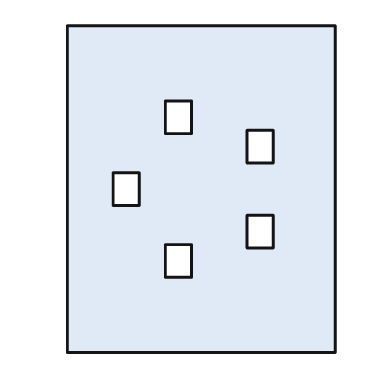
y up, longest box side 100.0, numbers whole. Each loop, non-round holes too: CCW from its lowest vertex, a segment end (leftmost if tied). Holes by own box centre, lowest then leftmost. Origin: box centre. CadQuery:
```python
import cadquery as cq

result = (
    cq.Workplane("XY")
    .moveTo(-41.0, -50.0)
    .lineTo(41.0, -50.0)
    .lineTo(41.0, 50.0)
    .lineTo(-41.0, 50.0)
    .close()
    .moveTo(-11.0, -27.0)
    .lineTo(-3.0, -27.0)
    .lineTo(-3.0, -17.0)
    .lineTo(-11.0, -17.0)
    .close()
    .moveTo(14.0, -18.0)
    .lineTo(22.0, -18.0)
    .lineTo(22.0, -8.0)
    .lineTo(14.0, -8.0)
    .close()
    .moveTo(-27.0, -5.0)
    .lineTo(-19.0, -5.0)
    .lineTo(-19.0, 5.0)
    .lineTo(-27.0, 5.0)
    .close()
    .moveTo(14.0, 8.0)
    .lineTo(22.0, 8.0)
    .lineTo(22.0, 18.0)
    .lineTo(14.0, 18.0)
    .close()
    .moveTo(-11.0, 17.0)
    .lineTo(-3.0, 17.0)
    .lineTo(-3.0, 27.0)
    .lineTo(-11.0, 27.0)
    .close()
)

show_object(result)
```